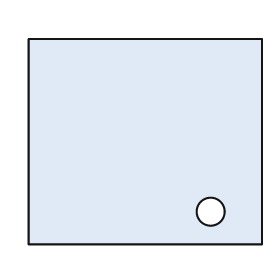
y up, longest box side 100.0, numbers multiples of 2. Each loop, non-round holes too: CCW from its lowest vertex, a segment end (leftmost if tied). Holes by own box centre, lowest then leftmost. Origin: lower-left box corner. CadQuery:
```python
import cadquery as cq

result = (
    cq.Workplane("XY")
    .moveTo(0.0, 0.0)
    .lineTo(100.0, 0.0)
    .lineTo(100.0, 88.0)
    .lineTo(0.0, 88.0)
    .close()
    .moveTo(78.0, 14.0)
    .circle(6.0)
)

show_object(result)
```